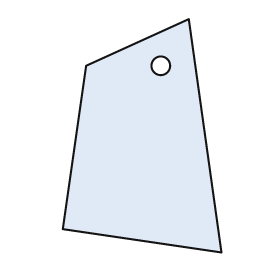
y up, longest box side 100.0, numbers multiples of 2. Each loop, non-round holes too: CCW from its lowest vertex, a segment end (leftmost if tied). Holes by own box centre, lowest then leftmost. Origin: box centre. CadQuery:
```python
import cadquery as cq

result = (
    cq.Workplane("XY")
    .moveTo(34.0, -50.0)
    .lineTo(20.0, 50.0)
    .lineTo(-24.0, 30.0)
    .lineTo(-34.0, -40.0)
    .close()
    .moveTo(8.0, 30.0)
    .circle(4.0)
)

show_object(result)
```